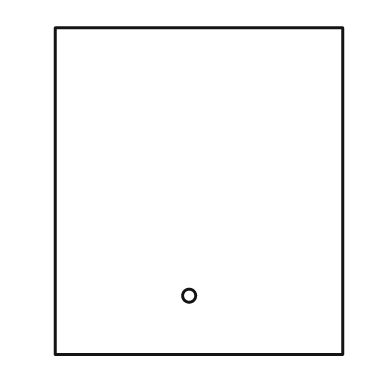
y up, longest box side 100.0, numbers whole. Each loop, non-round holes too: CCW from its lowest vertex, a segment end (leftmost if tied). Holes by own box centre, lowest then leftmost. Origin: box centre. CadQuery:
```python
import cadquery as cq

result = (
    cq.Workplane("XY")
    .moveTo(-44.0, -50.0)
    .lineTo(44.0, -50.0)
    .lineTo(44.0, 50.0)
    .lineTo(-44.0, 50.0)
    .close()
    .moveTo(-3.0, -32.0)
    .circle(2.0)
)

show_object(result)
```